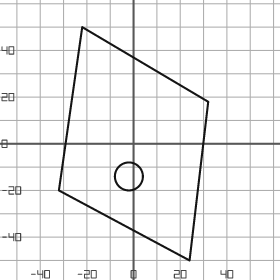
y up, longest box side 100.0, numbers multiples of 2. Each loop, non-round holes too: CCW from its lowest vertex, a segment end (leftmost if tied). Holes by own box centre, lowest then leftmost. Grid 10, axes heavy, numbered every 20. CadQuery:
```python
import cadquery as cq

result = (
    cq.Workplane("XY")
    .moveTo(24.0, -50.0)
    .lineTo(32.0, 18.0)
    .lineTo(-22.0, 50.0)
    .lineTo(-32.0, -20.0)
    .close()
    .moveTo(-2.0, -14.0)
    .circle(6.0)
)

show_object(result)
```